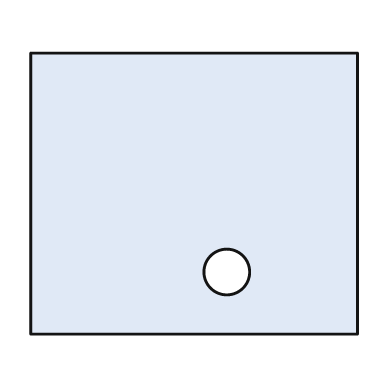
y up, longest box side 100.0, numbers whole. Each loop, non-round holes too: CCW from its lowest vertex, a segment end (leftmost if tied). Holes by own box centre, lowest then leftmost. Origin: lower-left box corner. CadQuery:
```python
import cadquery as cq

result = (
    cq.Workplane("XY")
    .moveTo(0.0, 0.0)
    .lineTo(100.0, 0.0)
    .lineTo(100.0, 86.0)
    .lineTo(0.0, 86.0)
    .close()
    .moveTo(60.0, 19.0)
    .circle(7.0)
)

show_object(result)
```